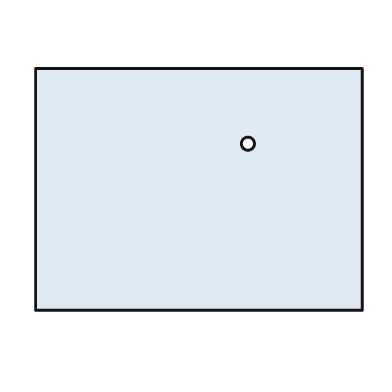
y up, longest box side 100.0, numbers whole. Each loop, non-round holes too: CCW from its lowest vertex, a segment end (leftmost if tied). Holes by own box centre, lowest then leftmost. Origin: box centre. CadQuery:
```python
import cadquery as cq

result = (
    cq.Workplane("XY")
    .moveTo(-50.0, -37.0)
    .lineTo(50.0, -37.0)
    .lineTo(50.0, 37.0)
    .lineTo(-50.0, 37.0)
    .close()
    .moveTo(15.0, 14.0)
    .circle(2.0)
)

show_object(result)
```